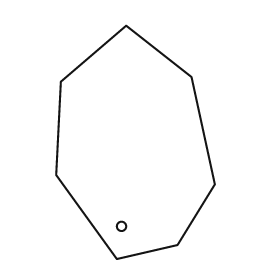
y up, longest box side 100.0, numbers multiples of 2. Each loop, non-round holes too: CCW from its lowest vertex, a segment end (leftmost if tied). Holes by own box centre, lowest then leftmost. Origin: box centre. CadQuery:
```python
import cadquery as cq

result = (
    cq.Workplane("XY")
    .moveTo(-8.0, -50.0)
    .lineTo(18.0, -44.0)
    .lineTo(34.0, -18.0)
    .lineTo(24.0, 28.0)
    .lineTo(-4.0, 50.0)
    .lineTo(-32.0, 26.0)
    .lineTo(-34.0, -14.0)
    .close()
    .moveTo(-6.0, -36.0)
    .circle(2.0)
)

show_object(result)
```